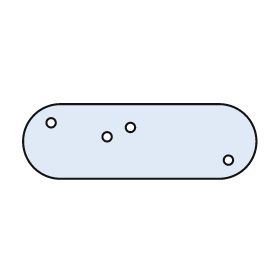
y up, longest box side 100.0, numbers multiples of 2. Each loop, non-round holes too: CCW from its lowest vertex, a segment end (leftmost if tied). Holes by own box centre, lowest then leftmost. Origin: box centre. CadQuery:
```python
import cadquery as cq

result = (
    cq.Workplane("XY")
    .moveTo(-34.0, -16.0)
    .lineTo(34.0, -16.0)
    .threePointArc((50.0, 0.0), (34.0, 16.0))
    .lineTo(-34.0, 16.0)
    .threePointArc((-50.0, 0.0), (-34.0, -16.0))
    .close()
    .moveTo(38.0, -8.0)
    .circle(2.0)
    .moveTo(-14.0, 2.0)
    .circle(2.0)
    .moveTo(-4.0, 6.0)
    .circle(2.0)
    .moveTo(-38.0, 8.0)
    .circle(2.0)
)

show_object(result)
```